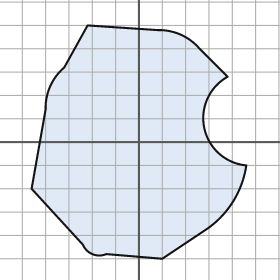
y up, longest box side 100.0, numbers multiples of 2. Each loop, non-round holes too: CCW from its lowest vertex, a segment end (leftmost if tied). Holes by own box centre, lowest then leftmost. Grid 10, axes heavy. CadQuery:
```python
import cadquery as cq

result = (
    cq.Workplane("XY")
    .moveTo(10.0, -50.0)
    .lineTo(28.0, -38.0)
    .threePointArc((40.0, -26.0), (46.0, -10.0))
    .threePointArc((28.0, 6.0), (38.0, 28.0))
    .lineTo(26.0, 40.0)
    .threePointArc((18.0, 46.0), (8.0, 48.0))
    .lineTo(-22.0, 50.0)
    .lineTo(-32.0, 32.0)
    .threePointArc((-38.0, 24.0), (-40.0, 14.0))
    .lineTo(-46.0, -20.0)
    .lineTo(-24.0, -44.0)
    .threePointArc((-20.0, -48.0), (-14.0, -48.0))
    .close()
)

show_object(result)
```